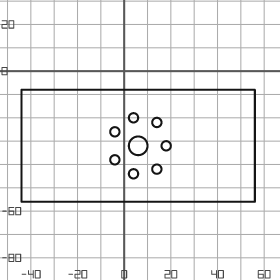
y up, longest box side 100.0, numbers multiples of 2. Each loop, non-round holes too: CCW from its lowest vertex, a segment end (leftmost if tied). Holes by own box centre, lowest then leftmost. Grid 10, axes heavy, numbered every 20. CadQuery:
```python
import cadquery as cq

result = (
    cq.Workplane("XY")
    .moveTo(-44.0, -56.0)
    .lineTo(56.0, -56.0)
    .lineTo(56.0, -8.0)
    .lineTo(-44.0, -8.0)
    .close()
    .moveTo(4.0, -44.0)
    .circle(2.0)
    .moveTo(14.0, -42.0)
    .circle(2.0)
    .moveTo(-4.0, -38.0)
    .circle(2.0)
    .moveTo(6.0, -32.0)
    .circle(4.0)
    .moveTo(18.0, -32.0)
    .circle(2.0)
    .moveTo(-4.0, -26.0)
    .circle(2.0)
    .moveTo(14.0, -22.0)
    .circle(2.0)
    .moveTo(4.0, -20.0)
    .circle(2.0)
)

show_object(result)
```